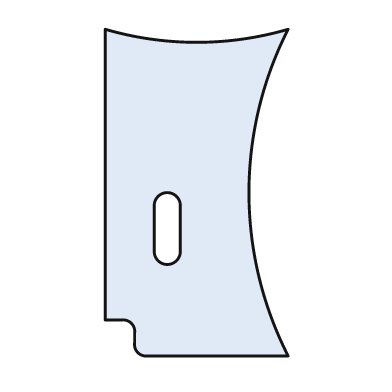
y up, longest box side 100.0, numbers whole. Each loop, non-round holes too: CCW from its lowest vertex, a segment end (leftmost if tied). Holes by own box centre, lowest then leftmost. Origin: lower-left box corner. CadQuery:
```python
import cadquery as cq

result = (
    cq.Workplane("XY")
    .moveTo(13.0, 0.0)
    .lineTo(56.0, 0.0)
    .threePointArc((44.0, 50.0), (56.0, 100.0))
    .threePointArc((28.0, 96.0), (0.0, 100.0))
    .lineTo(0.0, 11.0)
    .lineTo(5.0, 11.0)
    .threePointArc((8.0, 10.0), (9.0, 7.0))
    .lineTo(9.0, 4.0)
    .threePointArc((10.0, 1.0), (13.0, 0.0))
    .close()
    .moveTo(15.0, 32.0)
    .threePointArc((19.0, 28.0), (23.0, 32.0))
    .lineTo(23.0, 46.0)
    .threePointArc((19.0, 50.0), (15.0, 46.0))
    .close()
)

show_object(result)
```